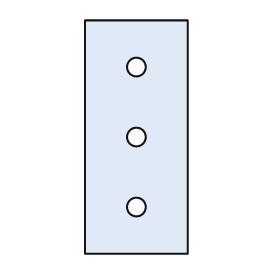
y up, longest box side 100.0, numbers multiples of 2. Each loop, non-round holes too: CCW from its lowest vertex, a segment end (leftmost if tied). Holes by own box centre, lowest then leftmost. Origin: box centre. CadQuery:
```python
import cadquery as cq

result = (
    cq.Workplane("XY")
    .moveTo(-22.0, -50.0)
    .lineTo(22.0, -50.0)
    .lineTo(22.0, 50.0)
    .lineTo(-22.0, 50.0)
    .close()
    .moveTo(0.0, -30.0)
    .circle(4.0)
    .moveTo(0.0, 0.0)
    .circle(4.0)
    .moveTo(0.0, 30.0)
    .circle(4.0)
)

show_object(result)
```